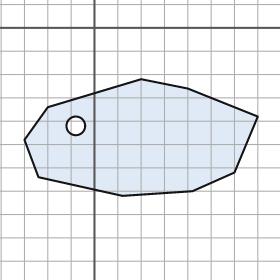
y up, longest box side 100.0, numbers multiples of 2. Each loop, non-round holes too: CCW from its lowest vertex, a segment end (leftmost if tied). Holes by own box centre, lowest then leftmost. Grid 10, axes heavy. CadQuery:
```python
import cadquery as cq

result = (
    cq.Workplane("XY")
    .moveTo(12.0, -72.0)
    .lineTo(42.0, -70.0)
    .lineTo(60.0, -62.0)
    .lineTo(70.0, -38.0)
    .lineTo(40.0, -26.0)
    .lineTo(20.0, -22.0)
    .lineTo(-20.0, -34.0)
    .lineTo(-30.0, -48.0)
    .lineTo(-24.0, -64.0)
    .close()
    .moveTo(-8.0, -42.0)
    .circle(4.0)
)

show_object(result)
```